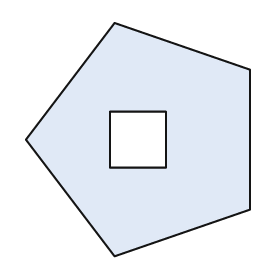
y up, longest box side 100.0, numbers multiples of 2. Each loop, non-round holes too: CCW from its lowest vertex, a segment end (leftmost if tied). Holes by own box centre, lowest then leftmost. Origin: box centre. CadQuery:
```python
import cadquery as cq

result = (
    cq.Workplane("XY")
    .moveTo(-10.0, -50.0)
    .lineTo(48.0, -30.0)
    .lineTo(48.0, 30.0)
    .lineTo(-10.0, 50.0)
    .lineTo(-48.0, 0.0)
    .close()
    .moveTo(-12.0, -12.0)
    .lineTo(12.0, -12.0)
    .lineTo(12.0, 12.0)
    .lineTo(-12.0, 12.0)
    .close()
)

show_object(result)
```